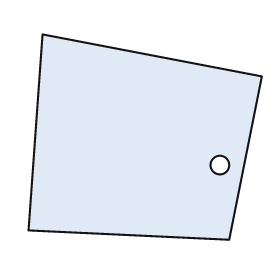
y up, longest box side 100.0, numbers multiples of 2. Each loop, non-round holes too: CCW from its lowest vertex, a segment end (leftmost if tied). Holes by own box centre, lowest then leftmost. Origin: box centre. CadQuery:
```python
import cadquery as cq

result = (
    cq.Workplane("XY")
    .moveTo(36.0, -44.0)
    .lineTo(50.0, 26.0)
    .lineTo(-44.0, 44.0)
    .lineTo(-50.0, -40.0)
    .close()
    .moveTo(32.0, -12.0)
    .circle(4.0)
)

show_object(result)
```